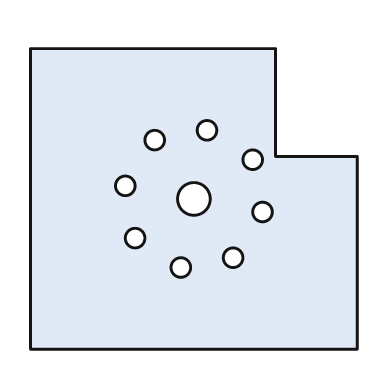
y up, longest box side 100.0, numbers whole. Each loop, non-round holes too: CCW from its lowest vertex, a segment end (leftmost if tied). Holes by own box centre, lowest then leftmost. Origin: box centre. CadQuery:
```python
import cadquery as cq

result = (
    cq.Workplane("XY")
    .moveTo(-50.0, -46.0)
    .lineTo(50.0, -46.0)
    .lineTo(50.0, 13.0)
    .lineTo(25.0, 13.0)
    .lineTo(25.0, 46.0)
    .lineTo(-50.0, 46.0)
    .close()
    .moveTo(-4.0, -21.0)
    .circle(3.0)
    .moveTo(12.0, -18.0)
    .circle(3.0)
    .moveTo(-18.0, -12.0)
    .circle(3.0)
    .moveTo(21.0, -4.0)
    .circle(3.0)
    .moveTo(0.0, 0.0)
    .circle(5.0)
    .moveTo(-21.0, 4.0)
    .circle(3.0)
    .moveTo(18.0, 12.0)
    .circle(3.0)
    .moveTo(-12.0, 18.0)
    .circle(3.0)
    .moveTo(4.0, 21.0)
    .circle(3.0)
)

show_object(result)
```